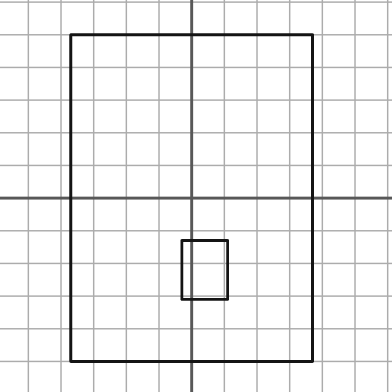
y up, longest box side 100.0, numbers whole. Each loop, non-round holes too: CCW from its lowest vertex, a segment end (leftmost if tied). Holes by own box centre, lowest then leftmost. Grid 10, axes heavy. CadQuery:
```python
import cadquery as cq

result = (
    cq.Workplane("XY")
    .moveTo(-37.0, -50.0)
    .lineTo(37.0, -50.0)
    .lineTo(37.0, 50.0)
    .lineTo(-37.0, 50.0)
    .close()
    .moveTo(-3.0, -31.0)
    .lineTo(11.0, -31.0)
    .lineTo(11.0, -13.0)
    .lineTo(-3.0, -13.0)
    .close()
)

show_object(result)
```